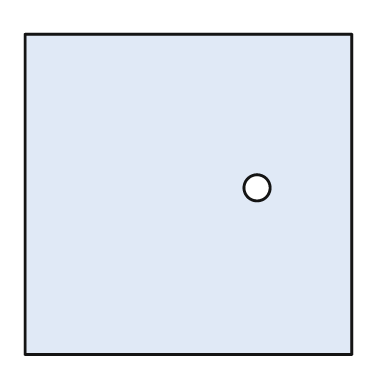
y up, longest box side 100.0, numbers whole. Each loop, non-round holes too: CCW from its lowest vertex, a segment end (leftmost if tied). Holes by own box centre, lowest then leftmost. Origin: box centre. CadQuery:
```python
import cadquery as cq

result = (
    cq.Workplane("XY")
    .moveTo(-50.0, -49.0)
    .lineTo(50.0, -49.0)
    .lineTo(50.0, 49.0)
    .lineTo(-50.0, 49.0)
    .close()
    .moveTo(21.0, 2.0)
    .circle(4.0)
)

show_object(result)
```